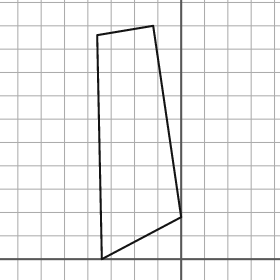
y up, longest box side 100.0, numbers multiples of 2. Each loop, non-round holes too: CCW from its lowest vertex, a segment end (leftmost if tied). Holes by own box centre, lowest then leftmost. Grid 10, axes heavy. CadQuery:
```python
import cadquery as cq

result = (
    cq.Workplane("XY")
    .moveTo(-34.0, 0.0)
    .lineTo(0.0, 18.0)
    .lineTo(-12.0, 100.0)
    .lineTo(-36.0, 96.0)
    .close()
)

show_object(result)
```